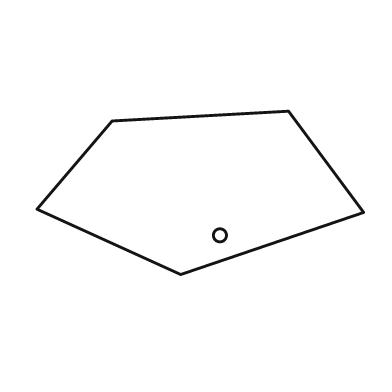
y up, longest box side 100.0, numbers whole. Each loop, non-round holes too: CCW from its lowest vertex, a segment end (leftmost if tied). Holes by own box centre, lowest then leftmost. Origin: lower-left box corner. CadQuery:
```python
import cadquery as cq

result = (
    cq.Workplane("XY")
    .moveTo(44.0, 0.0)
    .lineTo(100.0, 19.0)
    .lineTo(77.0, 50.0)
    .lineTo(23.0, 47.0)
    .lineTo(0.0, 20.0)
    .close()
    .moveTo(56.0, 12.0)
    .circle(2.0)
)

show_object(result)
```